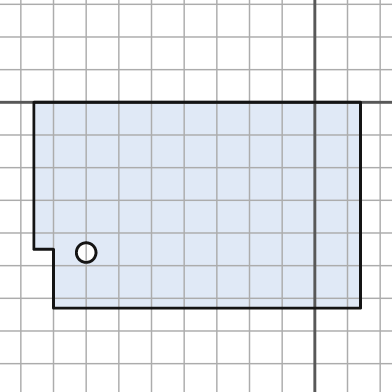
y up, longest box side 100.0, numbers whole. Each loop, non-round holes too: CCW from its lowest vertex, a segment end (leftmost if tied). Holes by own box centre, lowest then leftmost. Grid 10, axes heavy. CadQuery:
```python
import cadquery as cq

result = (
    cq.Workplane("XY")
    .moveTo(-80.0, -63.0)
    .lineTo(14.0, -63.0)
    .lineTo(14.0, 0.0)
    .lineTo(-86.0, 0.0)
    .lineTo(-86.0, -45.0)
    .lineTo(-80.0, -45.0)
    .close()
    .moveTo(-70.0, -46.0)
    .circle(3.0)
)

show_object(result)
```